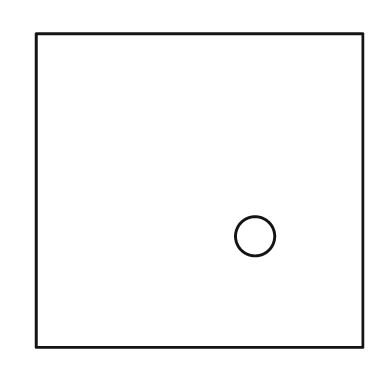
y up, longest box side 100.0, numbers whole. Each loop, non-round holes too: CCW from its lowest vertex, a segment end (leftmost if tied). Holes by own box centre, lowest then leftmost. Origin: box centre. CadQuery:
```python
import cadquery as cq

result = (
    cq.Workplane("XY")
    .moveTo(-50.0, -48.0)
    .lineTo(50.0, -48.0)
    .lineTo(50.0, 48.0)
    .lineTo(-50.0, 48.0)
    .close()
    .moveTo(17.0, -14.0)
    .circle(6.0)
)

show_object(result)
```